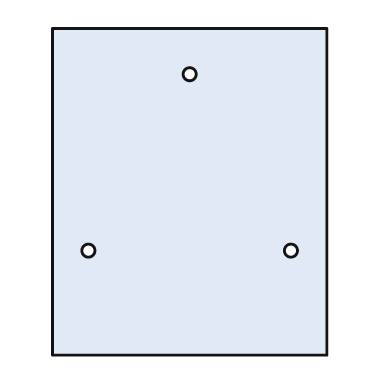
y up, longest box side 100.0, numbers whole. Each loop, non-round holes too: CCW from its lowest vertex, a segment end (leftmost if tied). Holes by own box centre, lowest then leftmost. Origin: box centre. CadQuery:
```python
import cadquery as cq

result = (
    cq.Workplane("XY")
    .moveTo(-42.0, -50.0)
    .lineTo(42.0, -50.0)
    .lineTo(42.0, 50.0)
    .lineTo(-42.0, 50.0)
    .close()
    .moveTo(-31.0, -18.0)
    .circle(2.0)
    .moveTo(31.0, -18.0)
    .circle(2.0)
    .moveTo(0.0, 36.0)
    .circle(2.0)
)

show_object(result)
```